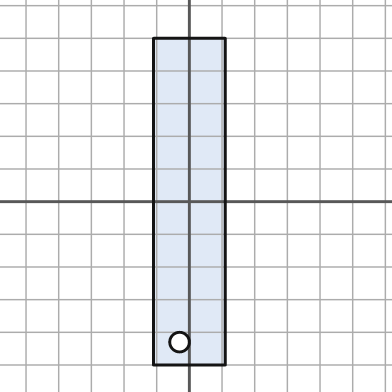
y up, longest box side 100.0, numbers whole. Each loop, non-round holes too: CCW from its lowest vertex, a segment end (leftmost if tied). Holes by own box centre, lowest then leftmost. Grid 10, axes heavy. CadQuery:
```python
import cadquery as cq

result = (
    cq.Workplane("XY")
    .moveTo(-11.0, -50.0)
    .lineTo(11.0, -50.0)
    .lineTo(11.0, 50.0)
    .lineTo(-11.0, 50.0)
    .close()
    .moveTo(-3.0, -43.0)
    .circle(3.0)
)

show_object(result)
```